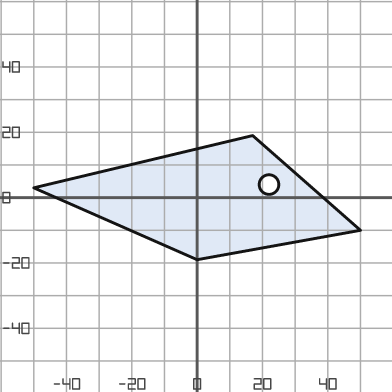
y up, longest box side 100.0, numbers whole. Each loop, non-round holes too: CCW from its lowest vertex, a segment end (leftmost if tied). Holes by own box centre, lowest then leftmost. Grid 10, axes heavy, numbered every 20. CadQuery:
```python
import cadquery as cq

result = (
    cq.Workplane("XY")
    .moveTo(0.0, -19.0)
    .lineTo(50.0, -10.0)
    .lineTo(17.0, 19.0)
    .lineTo(-50.0, 3.0)
    .close()
    .moveTo(22.0, 4.0)
    .circle(3.0)
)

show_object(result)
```